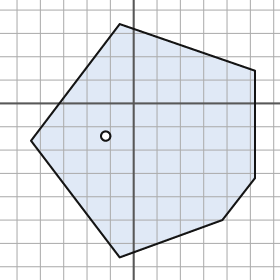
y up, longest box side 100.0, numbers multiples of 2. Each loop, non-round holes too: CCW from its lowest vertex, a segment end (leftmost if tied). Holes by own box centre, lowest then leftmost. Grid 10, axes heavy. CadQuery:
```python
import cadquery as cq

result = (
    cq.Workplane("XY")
    .moveTo(-6.0, -66.0)
    .lineTo(38.0, -50.0)
    .lineTo(52.0, -32.0)
    .lineTo(52.0, 14.0)
    .lineTo(-6.0, 34.0)
    .lineTo(-44.0, -16.0)
    .close()
    .moveTo(-12.0, -14.0)
    .circle(2.0)
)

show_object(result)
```